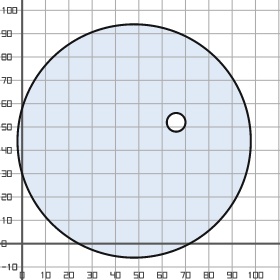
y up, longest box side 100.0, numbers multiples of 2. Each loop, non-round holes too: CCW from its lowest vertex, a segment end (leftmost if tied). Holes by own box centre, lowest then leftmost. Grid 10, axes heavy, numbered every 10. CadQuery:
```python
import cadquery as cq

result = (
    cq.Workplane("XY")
    .moveTo(48.0, 44.0)
    .circle(50.0)
    .moveTo(66.0, 52.0)
    .circle(4.0)
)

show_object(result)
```